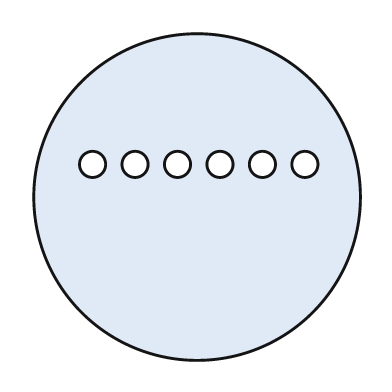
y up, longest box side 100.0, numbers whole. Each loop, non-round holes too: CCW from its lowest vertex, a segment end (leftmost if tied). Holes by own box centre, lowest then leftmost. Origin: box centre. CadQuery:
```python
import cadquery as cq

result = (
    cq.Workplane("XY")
    .moveTo(0.0, 0.0)
    .circle(50.0)
    .moveTo(-32.0, 10.0)
    .circle(4.0)
    .moveTo(-19.0, 10.0)
    .circle(4.0)
    .moveTo(-6.0, 10.0)
    .circle(4.0)
    .moveTo(7.0, 10.0)
    .circle(4.0)
    .moveTo(20.0, 10.0)
    .circle(4.0)
    .moveTo(33.0, 10.0)
    .circle(4.0)
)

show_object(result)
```